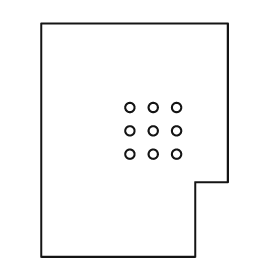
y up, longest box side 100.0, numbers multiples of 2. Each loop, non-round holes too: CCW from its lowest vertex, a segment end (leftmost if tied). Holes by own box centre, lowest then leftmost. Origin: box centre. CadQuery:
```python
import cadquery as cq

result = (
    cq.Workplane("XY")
    .moveTo(-40.0, -50.0)
    .lineTo(26.0, -50.0)
    .lineTo(26.0, -18.0)
    .lineTo(40.0, -18.0)
    .lineTo(40.0, 50.0)
    .lineTo(-40.0, 50.0)
    .close()
    .moveTo(-2.0, -6.0)
    .circle(2.0)
    .moveTo(8.0, -6.0)
    .circle(2.0)
    .moveTo(18.0, -6.0)
    .circle(2.0)
    .moveTo(-2.0, 4.0)
    .circle(2.0)
    .moveTo(8.0, 4.0)
    .circle(2.0)
    .moveTo(18.0, 4.0)
    .circle(2.0)
    .moveTo(-2.0, 14.0)
    .circle(2.0)
    .moveTo(8.0, 14.0)
    .circle(2.0)
    .moveTo(18.0, 14.0)
    .circle(2.0)
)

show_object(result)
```